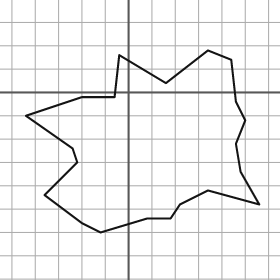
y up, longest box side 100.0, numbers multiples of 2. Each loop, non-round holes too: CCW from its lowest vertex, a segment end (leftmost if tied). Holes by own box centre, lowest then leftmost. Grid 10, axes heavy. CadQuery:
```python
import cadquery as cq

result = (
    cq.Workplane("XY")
    .moveTo(-12.0, -60.0)
    .lineTo(8.0, -54.0)
    .lineTo(18.0, -54.0)
    .lineTo(22.0, -48.0)
    .lineTo(34.0, -42.0)
    .lineTo(56.0, -48.0)
    .lineTo(48.0, -34.0)
    .lineTo(46.0, -22.0)
    .lineTo(50.0, -12.0)
    .lineTo(46.0, -4.0)
    .lineTo(44.0, 14.0)
    .lineTo(34.0, 18.0)
    .lineTo(16.0, 4.0)
    .lineTo(-4.0, 16.0)
    .lineTo(-6.0, -2.0)
    .lineTo(-20.0, -2.0)
    .lineTo(-44.0, -10.0)
    .lineTo(-24.0, -24.0)
    .lineTo(-22.0, -30.0)
    .lineTo(-36.0, -44.0)
    .lineTo(-20.0, -56.0)
    .close()
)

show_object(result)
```